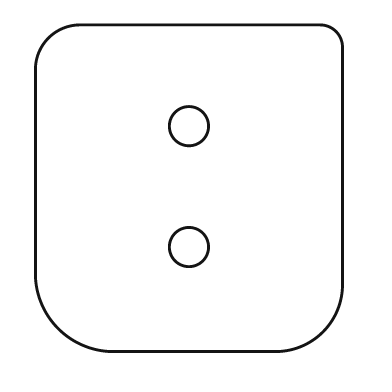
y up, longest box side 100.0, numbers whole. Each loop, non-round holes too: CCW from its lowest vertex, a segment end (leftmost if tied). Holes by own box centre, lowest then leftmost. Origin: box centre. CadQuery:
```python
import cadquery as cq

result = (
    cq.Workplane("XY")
    .moveTo(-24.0, -50.0)
    .lineTo(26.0, -50.0)
    .threePointArc((41.0, -44.0), (47.0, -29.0))
    .lineTo(47.0, 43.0)
    .threePointArc((45.0, 48.0), (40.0, 50.0))
    .lineTo(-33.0, 50.0)
    .threePointArc((-43.0, 46.0), (-47.0, 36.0))
    .lineTo(-47.0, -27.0)
    .threePointArc((-40.0, -43.0), (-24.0, -50.0))
    .close()
    .moveTo(0.0, -18.0)
    .circle(6.0)
    .moveTo(0.0, 19.0)
    .circle(6.0)
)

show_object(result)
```